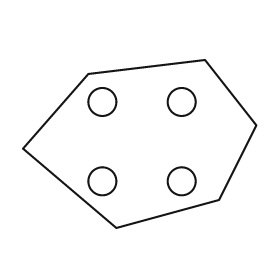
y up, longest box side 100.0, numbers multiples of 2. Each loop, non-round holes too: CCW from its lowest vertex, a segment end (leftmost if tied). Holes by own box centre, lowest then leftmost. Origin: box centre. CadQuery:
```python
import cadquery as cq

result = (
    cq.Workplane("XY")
    .moveTo(-10.0, -36.0)
    .lineTo(34.0, -24.0)
    .lineTo(50.0, 8.0)
    .lineTo(28.0, 36.0)
    .lineTo(-22.0, 30.0)
    .lineTo(-50.0, -2.0)
    .close()
    .moveTo(-16.0, -16.0)
    .circle(6.0)
    .moveTo(18.0, -16.0)
    .circle(6.0)
    .moveTo(-16.0, 18.0)
    .circle(6.0)
    .moveTo(18.0, 18.0)
    .circle(6.0)
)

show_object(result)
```